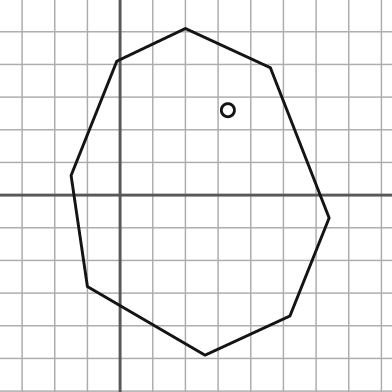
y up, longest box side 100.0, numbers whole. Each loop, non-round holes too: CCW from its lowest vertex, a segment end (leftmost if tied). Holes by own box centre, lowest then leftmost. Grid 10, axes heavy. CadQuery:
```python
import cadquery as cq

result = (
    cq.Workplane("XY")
    .moveTo(26.0, -49.0)
    .lineTo(52.0, -37.0)
    .lineTo(64.0, -7.0)
    .lineTo(46.0, 39.0)
    .lineTo(20.0, 51.0)
    .lineTo(-1.0, 41.0)
    .lineTo(-15.0, 6.0)
    .lineTo(-10.0, -28.0)
    .close()
    .moveTo(33.0, 26.0)
    .circle(2.0)
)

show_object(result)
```